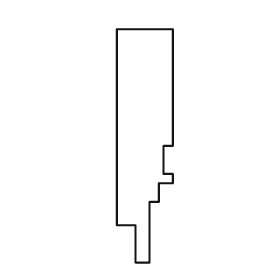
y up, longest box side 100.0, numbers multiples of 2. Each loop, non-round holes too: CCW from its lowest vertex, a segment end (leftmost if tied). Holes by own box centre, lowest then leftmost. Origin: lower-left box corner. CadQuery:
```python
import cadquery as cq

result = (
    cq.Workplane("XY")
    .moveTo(8.0, 0.0)
    .lineTo(14.0, 0.0)
    .lineTo(14.0, 26.0)
    .lineTo(18.0, 26.0)
    .lineTo(18.0, 34.0)
    .lineTo(24.0, 34.0)
    .lineTo(24.0, 38.0)
    .lineTo(20.0, 38.0)
    .lineTo(20.0, 50.0)
    .lineTo(24.0, 50.0)
    .lineTo(24.0, 100.0)
    .lineTo(0.0, 100.0)
    .lineTo(0.0, 16.0)
    .lineTo(8.0, 16.0)
    .close()
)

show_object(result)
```